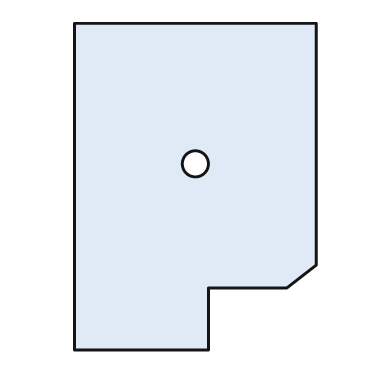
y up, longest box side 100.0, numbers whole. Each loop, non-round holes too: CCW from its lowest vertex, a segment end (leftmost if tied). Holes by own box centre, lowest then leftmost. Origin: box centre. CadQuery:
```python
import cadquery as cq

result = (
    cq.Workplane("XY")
    .moveTo(-37.0, -50.0)
    .lineTo(4.0, -50.0)
    .lineTo(4.0, -31.0)
    .lineTo(28.0, -31.0)
    .lineTo(37.0, -24.0)
    .lineTo(37.0, 50.0)
    .lineTo(-37.0, 50.0)
    .close()
    .moveTo(0.0, 7.0)
    .circle(4.0)
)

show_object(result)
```